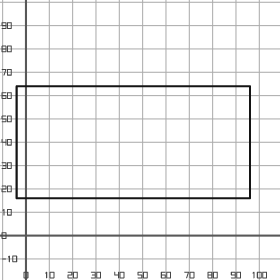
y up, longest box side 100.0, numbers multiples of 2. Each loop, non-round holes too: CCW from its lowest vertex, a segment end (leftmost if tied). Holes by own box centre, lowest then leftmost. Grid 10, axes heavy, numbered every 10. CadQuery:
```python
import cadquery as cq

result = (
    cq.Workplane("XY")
    .moveTo(-4.0, 16.0)
    .lineTo(96.0, 16.0)
    .lineTo(96.0, 64.0)
    .lineTo(-4.0, 64.0)
    .close()
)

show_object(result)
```